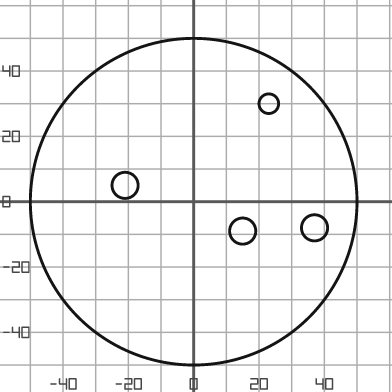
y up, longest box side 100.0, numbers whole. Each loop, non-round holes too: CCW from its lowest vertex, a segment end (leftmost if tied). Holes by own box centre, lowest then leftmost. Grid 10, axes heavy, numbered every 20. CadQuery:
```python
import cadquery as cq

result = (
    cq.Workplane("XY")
    .moveTo(0.0, 0.0)
    .circle(50.0)
    .moveTo(15.0, -9.0)
    .circle(4.0)
    .moveTo(37.0, -8.0)
    .circle(4.0)
    .moveTo(-21.0, 5.0)
    .circle(4.0)
    .moveTo(23.0, 30.0)
    .circle(3.0)
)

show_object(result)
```